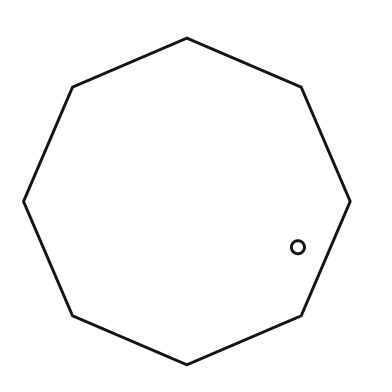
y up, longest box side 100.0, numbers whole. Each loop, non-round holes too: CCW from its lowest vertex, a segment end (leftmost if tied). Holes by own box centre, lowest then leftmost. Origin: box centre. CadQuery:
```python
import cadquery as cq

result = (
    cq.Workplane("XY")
    .moveTo(0.0, -50.0)
    .lineTo(35.0, -35.0)
    .lineTo(50.0, 0.0)
    .lineTo(35.0, 35.0)
    .lineTo(0.0, 50.0)
    .lineTo(-35.0, 35.0)
    .lineTo(-50.0, 0.0)
    .lineTo(-35.0, -35.0)
    .close()
    .moveTo(34.0, -14.0)
    .circle(2.0)
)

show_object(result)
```